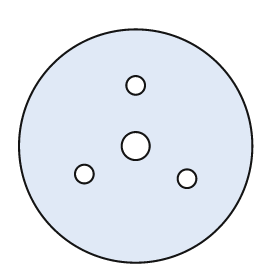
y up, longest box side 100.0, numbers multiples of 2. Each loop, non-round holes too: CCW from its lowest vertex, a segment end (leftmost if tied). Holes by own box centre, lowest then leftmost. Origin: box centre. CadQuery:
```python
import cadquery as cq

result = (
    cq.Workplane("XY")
    .moveTo(0.0, 0.0)
    .circle(50.0)
    .moveTo(22.0, -14.0)
    .circle(4.0)
    .moveTo(-22.0, -12.0)
    .circle(4.0)
    .moveTo(0.0, 0.0)
    .circle(6.0)
    .moveTo(0.0, 26.0)
    .circle(4.0)
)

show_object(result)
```